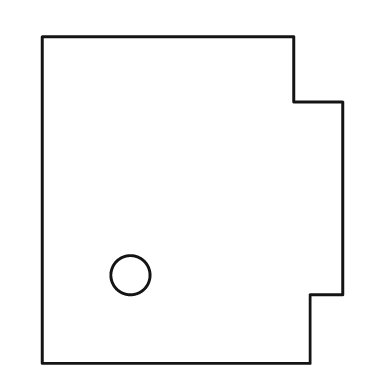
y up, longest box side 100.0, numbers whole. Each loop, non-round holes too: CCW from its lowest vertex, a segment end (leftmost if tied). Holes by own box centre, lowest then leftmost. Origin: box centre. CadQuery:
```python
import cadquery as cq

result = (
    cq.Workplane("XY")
    .moveTo(-46.0, -50.0)
    .lineTo(36.0, -50.0)
    .lineTo(36.0, -29.0)
    .lineTo(46.0, -29.0)
    .lineTo(46.0, 30.0)
    .lineTo(31.0, 30.0)
    .lineTo(31.0, 50.0)
    .lineTo(-46.0, 50.0)
    .close()
    .moveTo(-19.0, -23.0)
    .circle(6.0)
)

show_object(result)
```